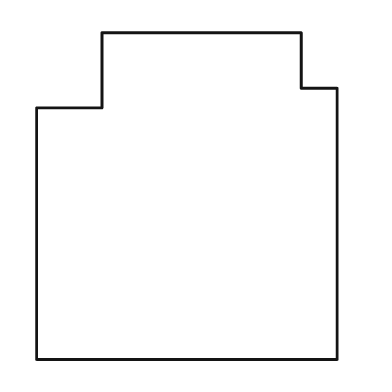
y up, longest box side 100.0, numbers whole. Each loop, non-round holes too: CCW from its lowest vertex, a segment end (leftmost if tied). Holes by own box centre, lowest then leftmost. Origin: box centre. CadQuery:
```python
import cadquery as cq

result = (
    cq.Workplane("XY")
    .moveTo(-46.0, -50.0)
    .lineTo(46.0, -50.0)
    .lineTo(46.0, 33.0)
    .lineTo(35.0, 33.0)
    .lineTo(35.0, 50.0)
    .lineTo(-26.0, 50.0)
    .lineTo(-26.0, 27.0)
    .lineTo(-46.0, 27.0)
    .close()
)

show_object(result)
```